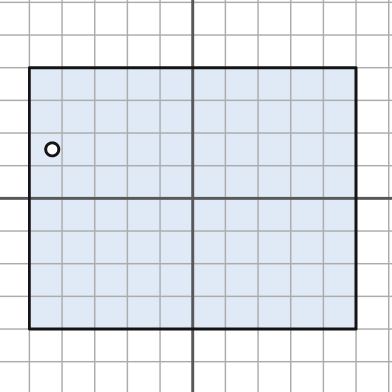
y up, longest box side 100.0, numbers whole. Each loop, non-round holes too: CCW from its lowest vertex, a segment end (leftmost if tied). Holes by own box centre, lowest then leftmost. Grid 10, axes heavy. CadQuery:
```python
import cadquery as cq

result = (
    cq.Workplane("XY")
    .moveTo(-50.0, -40.0)
    .lineTo(50.0, -40.0)
    .lineTo(50.0, 40.0)
    .lineTo(-50.0, 40.0)
    .close()
    .moveTo(-43.0, 15.0)
    .circle(2.0)
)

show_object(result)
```